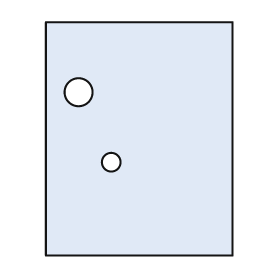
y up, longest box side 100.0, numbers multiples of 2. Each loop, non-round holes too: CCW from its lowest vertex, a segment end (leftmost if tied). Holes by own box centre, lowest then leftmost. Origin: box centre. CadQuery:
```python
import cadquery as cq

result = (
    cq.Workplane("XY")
    .moveTo(-40.0, -50.0)
    .lineTo(40.0, -50.0)
    .lineTo(40.0, 50.0)
    .lineTo(-40.0, 50.0)
    .close()
    .moveTo(-12.0, -10.0)
    .circle(4.0)
    .moveTo(-26.0, 20.0)
    .circle(6.0)
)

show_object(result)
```